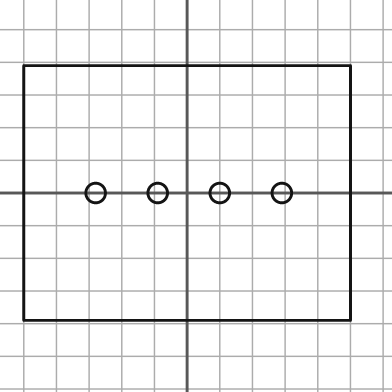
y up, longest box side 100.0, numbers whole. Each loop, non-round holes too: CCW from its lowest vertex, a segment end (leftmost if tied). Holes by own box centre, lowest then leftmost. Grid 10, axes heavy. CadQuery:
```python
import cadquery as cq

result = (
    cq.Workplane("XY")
    .moveTo(-50.0, -39.0)
    .lineTo(50.0, -39.0)
    .lineTo(50.0, 39.0)
    .lineTo(-50.0, 39.0)
    .close()
    .moveTo(-28.0, 0.0)
    .circle(3.0)
    .moveTo(-9.0, 0.0)
    .circle(3.0)
    .moveTo(10.0, 0.0)
    .circle(3.0)
    .moveTo(29.0, 0.0)
    .circle(3.0)
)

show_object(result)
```